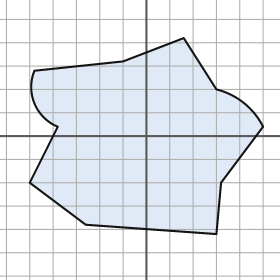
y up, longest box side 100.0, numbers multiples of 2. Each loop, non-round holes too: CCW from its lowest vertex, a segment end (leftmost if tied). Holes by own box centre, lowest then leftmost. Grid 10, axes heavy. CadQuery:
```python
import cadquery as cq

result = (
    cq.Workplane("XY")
    .moveTo(30.0, -42.0)
    .lineTo(32.0, -20.0)
    .lineTo(50.0, 4.0)
    .threePointArc((42.0, 14.0), (30.0, 20.0))
    .lineTo(16.0, 42.0)
    .lineTo(-10.0, 32.0)
    .lineTo(-48.0, 28.0)
    .threePointArc((-48.0, 14.0), (-38.0, 4.0))
    .lineTo(-50.0, -20.0)
    .lineTo(-26.0, -38.0)
    .close()
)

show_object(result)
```